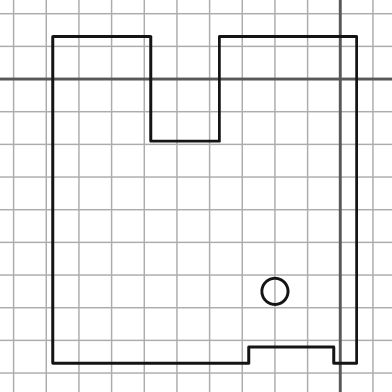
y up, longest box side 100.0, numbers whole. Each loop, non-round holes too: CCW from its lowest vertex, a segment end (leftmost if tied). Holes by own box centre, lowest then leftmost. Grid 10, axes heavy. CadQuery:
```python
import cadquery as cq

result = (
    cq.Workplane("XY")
    .moveTo(-88.0, -87.0)
    .lineTo(-28.0, -87.0)
    .lineTo(-28.0, -82.0)
    .lineTo(-2.0, -82.0)
    .lineTo(-2.0, -87.0)
    .lineTo(5.0, -87.0)
    .lineTo(5.0, 13.0)
    .lineTo(-37.0, 13.0)
    .lineTo(-37.0, -19.0)
    .lineTo(-58.0, -19.0)
    .lineTo(-58.0, 13.0)
    .lineTo(-88.0, 13.0)
    .close()
    .moveTo(-20.0, -65.0)
    .circle(4.0)
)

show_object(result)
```